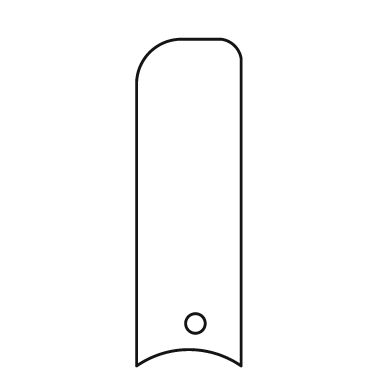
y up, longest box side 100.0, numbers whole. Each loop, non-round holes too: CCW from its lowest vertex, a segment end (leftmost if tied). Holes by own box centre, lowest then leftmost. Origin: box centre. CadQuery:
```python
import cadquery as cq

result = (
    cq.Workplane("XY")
    .moveTo(-16.0, -50.0)
    .threePointArc((0.0, -45.0), (16.0, -50.0))
    .lineTo(16.0, 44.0)
    .threePointArc((14.0, 48.0), (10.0, 50.0))
    .lineTo(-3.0, 50.0)
    .threePointArc((-12.0, 46.0), (-16.0, 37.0))
    .close()
    .moveTo(2.0, -37.0)
    .circle(3.0)
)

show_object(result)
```